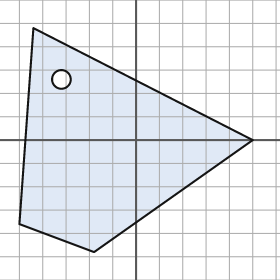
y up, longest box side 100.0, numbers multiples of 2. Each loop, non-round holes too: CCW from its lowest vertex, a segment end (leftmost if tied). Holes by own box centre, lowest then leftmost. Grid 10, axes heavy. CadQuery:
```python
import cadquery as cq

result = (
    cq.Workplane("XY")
    .moveTo(-18.0, -48.0)
    .lineTo(50.0, 0.0)
    .lineTo(-44.0, 48.0)
    .lineTo(-50.0, -36.0)
    .close()
    .moveTo(-32.0, 26.0)
    .circle(4.0)
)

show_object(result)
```